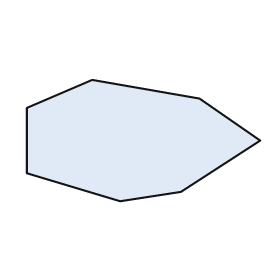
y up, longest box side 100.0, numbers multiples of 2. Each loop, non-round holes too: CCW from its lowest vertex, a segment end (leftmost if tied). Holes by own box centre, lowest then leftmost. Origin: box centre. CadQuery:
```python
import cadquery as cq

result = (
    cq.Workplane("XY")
    .moveTo(-10.0, -26.0)
    .lineTo(16.0, -22.0)
    .lineTo(50.0, 0.0)
    .lineTo(24.0, 18.0)
    .lineTo(-22.0, 26.0)
    .lineTo(-50.0, 14.0)
    .lineTo(-50.0, -14.0)
    .close()
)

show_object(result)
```